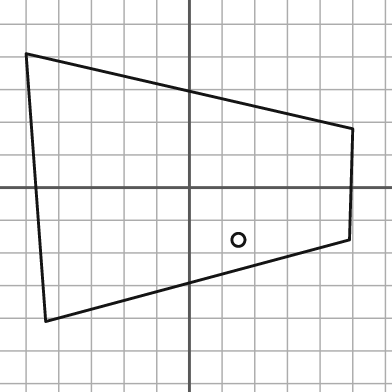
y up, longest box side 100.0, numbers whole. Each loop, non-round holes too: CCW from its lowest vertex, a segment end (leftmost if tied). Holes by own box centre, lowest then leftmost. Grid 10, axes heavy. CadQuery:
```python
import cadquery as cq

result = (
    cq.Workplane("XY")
    .moveTo(-44.0, -41.0)
    .lineTo(49.0, -16.0)
    .lineTo(50.0, 18.0)
    .lineTo(-50.0, 41.0)
    .close()
    .moveTo(15.0, -16.0)
    .circle(2.0)
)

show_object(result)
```